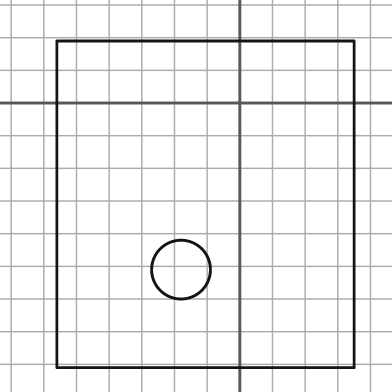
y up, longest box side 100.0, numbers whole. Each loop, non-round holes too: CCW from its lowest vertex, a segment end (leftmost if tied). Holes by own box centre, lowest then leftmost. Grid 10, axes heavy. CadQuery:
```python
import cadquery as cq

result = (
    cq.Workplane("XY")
    .moveTo(-56.0, -81.0)
    .lineTo(35.0, -81.0)
    .lineTo(35.0, 19.0)
    .lineTo(-56.0, 19.0)
    .close()
    .moveTo(-18.0, -51.0)
    .circle(9.0)
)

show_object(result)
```